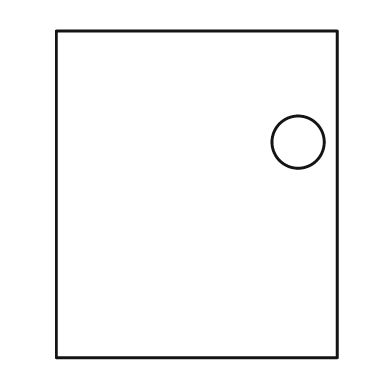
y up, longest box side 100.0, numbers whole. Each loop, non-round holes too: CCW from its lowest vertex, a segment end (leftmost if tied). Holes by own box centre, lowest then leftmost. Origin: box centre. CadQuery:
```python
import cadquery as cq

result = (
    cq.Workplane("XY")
    .moveTo(-43.0, -50.0)
    .lineTo(43.0, -50.0)
    .lineTo(43.0, 50.0)
    .lineTo(-43.0, 50.0)
    .close()
    .moveTo(31.0, 16.0)
    .circle(8.0)
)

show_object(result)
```